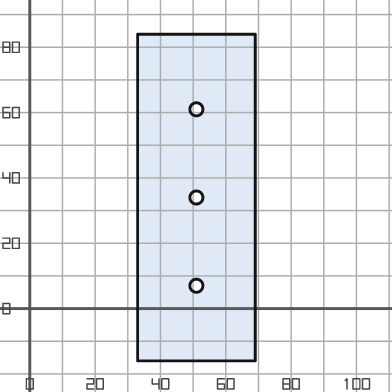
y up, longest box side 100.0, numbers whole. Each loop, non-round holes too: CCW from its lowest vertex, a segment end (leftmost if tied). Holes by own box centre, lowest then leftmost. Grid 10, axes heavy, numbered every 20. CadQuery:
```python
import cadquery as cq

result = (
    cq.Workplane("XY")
    .moveTo(33.0, -16.0)
    .lineTo(69.0, -16.0)
    .lineTo(69.0, 84.0)
    .lineTo(33.0, 84.0)
    .close()
    .moveTo(51.0, 7.0)
    .circle(2.0)
    .moveTo(51.0, 34.0)
    .circle(2.0)
    .moveTo(51.0, 61.0)
    .circle(2.0)
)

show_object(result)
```